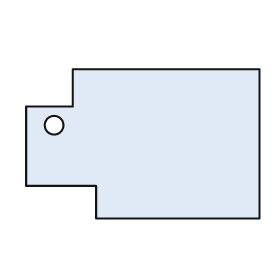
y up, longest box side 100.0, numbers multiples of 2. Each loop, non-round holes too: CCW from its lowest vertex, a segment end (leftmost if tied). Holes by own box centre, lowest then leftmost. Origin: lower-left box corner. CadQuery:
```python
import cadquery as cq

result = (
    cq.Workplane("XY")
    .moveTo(30.0, 0.0)
    .lineTo(100.0, 0.0)
    .lineTo(100.0, 64.0)
    .lineTo(20.0, 64.0)
    .lineTo(20.0, 48.0)
    .lineTo(0.0, 48.0)
    .lineTo(0.0, 14.0)
    .lineTo(30.0, 14.0)
    .close()
    .moveTo(12.0, 40.0)
    .circle(4.0)
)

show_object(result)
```